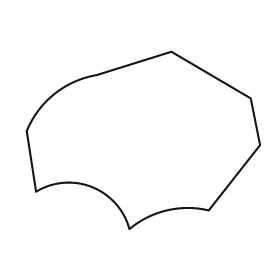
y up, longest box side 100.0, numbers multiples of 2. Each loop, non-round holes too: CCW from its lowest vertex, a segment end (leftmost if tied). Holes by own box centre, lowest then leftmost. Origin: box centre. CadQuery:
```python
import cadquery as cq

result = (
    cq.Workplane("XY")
    .moveTo(-6.0, -38.0)
    .threePointArc((10.0, -30.0), (28.0, -30.0))
    .lineTo(50.0, -2.0)
    .lineTo(46.0, 18.0)
    .lineTo(12.0, 38.0)
    .lineTo(-20.0, 28.0)
    .threePointArc((-38.0, 20.0), (-50.0, 4.0))
    .lineTo(-46.0, -22.0)
    .threePointArc((-22.0, -20.0), (-6.0, -38.0))
    .close()
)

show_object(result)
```